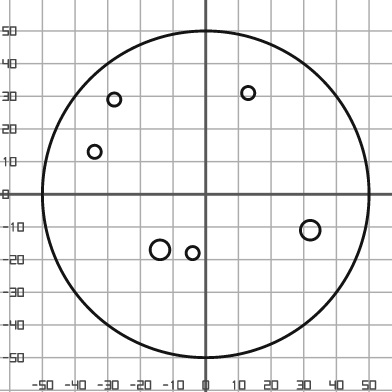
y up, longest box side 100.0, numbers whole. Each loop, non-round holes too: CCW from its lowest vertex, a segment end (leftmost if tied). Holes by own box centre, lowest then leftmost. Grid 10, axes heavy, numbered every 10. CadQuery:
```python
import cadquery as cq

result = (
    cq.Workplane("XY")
    .moveTo(0.0, 0.0)
    .circle(50.0)
    .moveTo(-4.0, -18.0)
    .circle(2.0)
    .moveTo(-14.0, -17.0)
    .circle(3.0)
    .moveTo(32.0, -11.0)
    .circle(3.0)
    .moveTo(-34.0, 13.0)
    .circle(2.0)
    .moveTo(-28.0, 29.0)
    .circle(2.0)
    .moveTo(13.0, 31.0)
    .circle(2.0)
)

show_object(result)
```